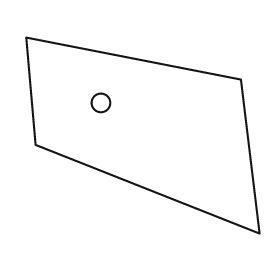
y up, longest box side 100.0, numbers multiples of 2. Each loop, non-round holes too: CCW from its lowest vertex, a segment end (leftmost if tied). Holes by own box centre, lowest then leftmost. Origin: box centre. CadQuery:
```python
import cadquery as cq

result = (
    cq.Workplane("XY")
    .moveTo(50.0, -42.0)
    .lineTo(42.0, 24.0)
    .lineTo(-50.0, 42.0)
    .lineTo(-46.0, -4.0)
    .close()
    .moveTo(-18.0, 14.0)
    .circle(4.0)
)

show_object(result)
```